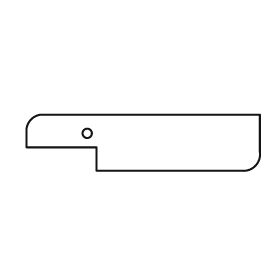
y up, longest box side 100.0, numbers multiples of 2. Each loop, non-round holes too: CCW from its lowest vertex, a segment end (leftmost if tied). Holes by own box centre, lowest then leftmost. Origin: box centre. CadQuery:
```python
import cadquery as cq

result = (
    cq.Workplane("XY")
    .moveTo(-20.0, -12.0)
    .lineTo(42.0, -12.0)
    .threePointArc((48.0, -10.0), (50.0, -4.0))
    .lineTo(50.0, 12.0)
    .lineTo(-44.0, 12.0)
    .threePointArc((-48.0, 10.0), (-50.0, 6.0))
    .lineTo(-50.0, -2.0)
    .lineTo(-20.0, -2.0)
    .close()
    .moveTo(-24.0, 4.0)
    .circle(2.0)
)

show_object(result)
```